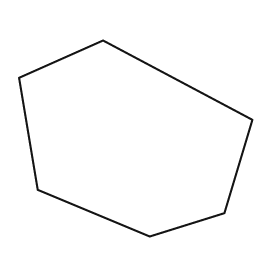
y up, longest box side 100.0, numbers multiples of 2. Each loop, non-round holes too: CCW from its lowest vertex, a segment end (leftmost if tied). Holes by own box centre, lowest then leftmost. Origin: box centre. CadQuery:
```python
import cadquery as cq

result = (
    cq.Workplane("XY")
    .moveTo(6.0, -42.0)
    .lineTo(38.0, -32.0)
    .lineTo(50.0, 8.0)
    .lineTo(-14.0, 42.0)
    .lineTo(-50.0, 26.0)
    .lineTo(-42.0, -22.0)
    .close()
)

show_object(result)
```